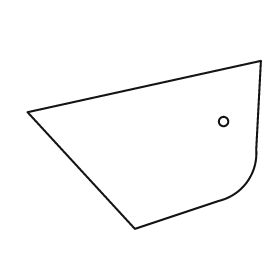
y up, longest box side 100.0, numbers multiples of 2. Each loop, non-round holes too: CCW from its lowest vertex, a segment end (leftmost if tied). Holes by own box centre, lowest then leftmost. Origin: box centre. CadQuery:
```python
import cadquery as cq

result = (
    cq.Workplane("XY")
    .moveTo(-4.0, -36.0)
    .lineTo(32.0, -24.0)
    .threePointArc((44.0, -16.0), (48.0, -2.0))
    .lineTo(50.0, 36.0)
    .lineTo(-50.0, 14.0)
    .close()
    .moveTo(34.0, 10.0)
    .circle(2.0)
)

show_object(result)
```